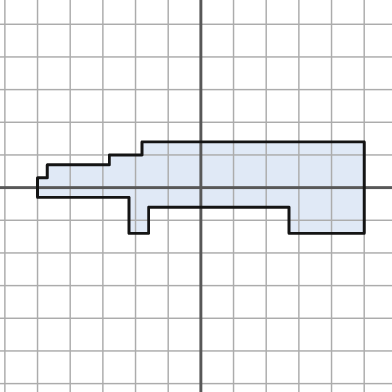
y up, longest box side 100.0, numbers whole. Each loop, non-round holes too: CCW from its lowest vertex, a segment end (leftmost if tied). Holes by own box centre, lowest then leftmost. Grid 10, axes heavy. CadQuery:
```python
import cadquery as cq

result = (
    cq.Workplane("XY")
    .moveTo(-22.0, -14.0)
    .lineTo(-16.0, -14.0)
    .lineTo(-16.0, -6.0)
    .lineTo(27.0, -6.0)
    .lineTo(27.0, -14.0)
    .lineTo(50.0, -14.0)
    .lineTo(50.0, 14.0)
    .lineTo(-18.0, 14.0)
    .lineTo(-18.0, 10.0)
    .lineTo(-28.0, 10.0)
    .lineTo(-28.0, 7.0)
    .lineTo(-47.0, 7.0)
    .lineTo(-47.0, 3.0)
    .lineTo(-50.0, 3.0)
    .lineTo(-50.0, -3.0)
    .lineTo(-22.0, -3.0)
    .close()
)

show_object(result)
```